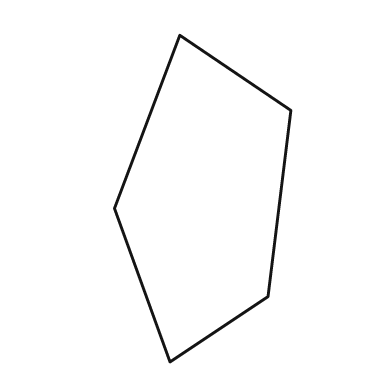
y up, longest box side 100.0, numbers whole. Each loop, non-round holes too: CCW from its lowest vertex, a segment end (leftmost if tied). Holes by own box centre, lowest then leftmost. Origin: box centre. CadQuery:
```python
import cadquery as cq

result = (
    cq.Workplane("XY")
    .moveTo(-10.0, -50.0)
    .lineTo(20.0, -30.0)
    .lineTo(27.0, 27.0)
    .lineTo(-7.0, 50.0)
    .lineTo(-27.0, -3.0)
    .close()
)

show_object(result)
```